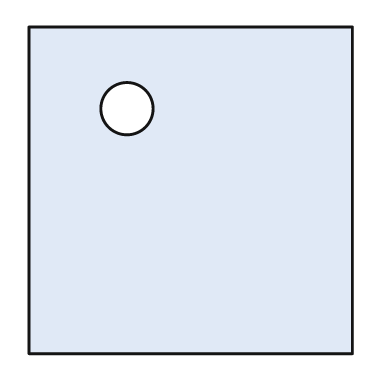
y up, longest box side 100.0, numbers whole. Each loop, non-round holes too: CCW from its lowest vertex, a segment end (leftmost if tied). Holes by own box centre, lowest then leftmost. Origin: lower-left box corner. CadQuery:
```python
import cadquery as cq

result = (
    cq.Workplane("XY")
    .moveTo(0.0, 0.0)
    .lineTo(99.0, 0.0)
    .lineTo(99.0, 100.0)
    .lineTo(0.0, 100.0)
    .close()
    .moveTo(30.0, 75.0)
    .circle(8.0)
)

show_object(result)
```